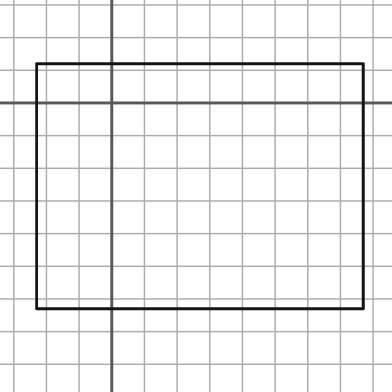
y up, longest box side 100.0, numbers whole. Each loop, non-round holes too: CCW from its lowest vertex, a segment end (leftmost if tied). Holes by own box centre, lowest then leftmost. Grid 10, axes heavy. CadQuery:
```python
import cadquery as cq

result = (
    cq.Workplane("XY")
    .moveTo(-23.0, -63.0)
    .lineTo(77.0, -63.0)
    .lineTo(77.0, 12.0)
    .lineTo(-23.0, 12.0)
    .close()
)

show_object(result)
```